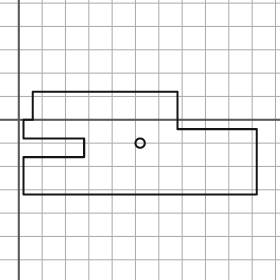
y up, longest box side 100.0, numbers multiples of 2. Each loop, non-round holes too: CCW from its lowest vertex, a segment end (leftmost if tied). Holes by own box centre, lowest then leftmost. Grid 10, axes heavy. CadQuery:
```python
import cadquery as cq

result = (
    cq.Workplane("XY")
    .moveTo(2.0, -32.0)
    .lineTo(102.0, -32.0)
    .lineTo(102.0, -4.0)
    .lineTo(68.0, -4.0)
    .lineTo(68.0, 12.0)
    .lineTo(6.0, 12.0)
    .lineTo(6.0, 0.0)
    .lineTo(2.0, 0.0)
    .lineTo(2.0, -8.0)
    .lineTo(28.0, -8.0)
    .lineTo(28.0, -16.0)
    .lineTo(2.0, -16.0)
    .close()
    .moveTo(52.0, -10.0)
    .circle(2.0)
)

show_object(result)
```